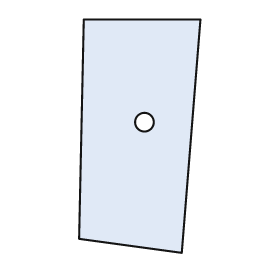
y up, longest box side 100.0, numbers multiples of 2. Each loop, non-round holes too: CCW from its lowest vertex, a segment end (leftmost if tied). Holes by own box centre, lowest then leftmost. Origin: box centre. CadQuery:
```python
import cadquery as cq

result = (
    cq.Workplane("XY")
    .moveTo(18.0, -50.0)
    .lineTo(26.0, 50.0)
    .lineTo(-24.0, 50.0)
    .lineTo(-26.0, -44.0)
    .close()
    .moveTo(2.0, 6.0)
    .circle(4.0)
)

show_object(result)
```